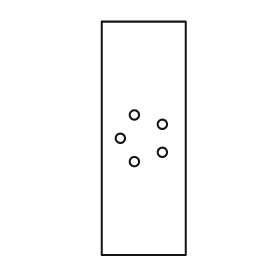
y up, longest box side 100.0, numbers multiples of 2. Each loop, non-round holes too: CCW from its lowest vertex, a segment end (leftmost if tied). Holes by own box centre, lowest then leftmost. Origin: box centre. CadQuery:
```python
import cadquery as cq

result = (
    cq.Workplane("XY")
    .moveTo(-18.0, -50.0)
    .lineTo(18.0, -50.0)
    .lineTo(18.0, 50.0)
    .lineTo(-18.0, 50.0)
    .close()
    .moveTo(-4.0, -10.0)
    .circle(2.0)
    .moveTo(8.0, -6.0)
    .circle(2.0)
    .moveTo(-10.0, 0.0)
    .circle(2.0)
    .moveTo(8.0, 6.0)
    .circle(2.0)
    .moveTo(-4.0, 10.0)
    .circle(2.0)
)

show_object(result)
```